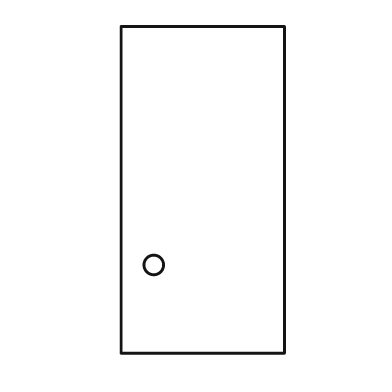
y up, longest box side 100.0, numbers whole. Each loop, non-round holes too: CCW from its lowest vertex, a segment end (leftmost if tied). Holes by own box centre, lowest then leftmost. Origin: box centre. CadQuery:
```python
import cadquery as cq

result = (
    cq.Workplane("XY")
    .moveTo(-25.0, -50.0)
    .lineTo(25.0, -50.0)
    .lineTo(25.0, 50.0)
    .lineTo(-25.0, 50.0)
    .close()
    .moveTo(-15.0, -23.0)
    .circle(3.0)
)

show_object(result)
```